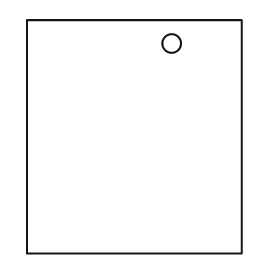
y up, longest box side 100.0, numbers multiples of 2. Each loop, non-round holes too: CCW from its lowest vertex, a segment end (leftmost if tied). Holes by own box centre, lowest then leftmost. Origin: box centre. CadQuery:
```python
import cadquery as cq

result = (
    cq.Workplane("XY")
    .moveTo(-46.0, -50.0)
    .lineTo(46.0, -50.0)
    .lineTo(46.0, 50.0)
    .lineTo(-46.0, 50.0)
    .close()
    .moveTo(16.0, 40.0)
    .circle(4.0)
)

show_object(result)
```